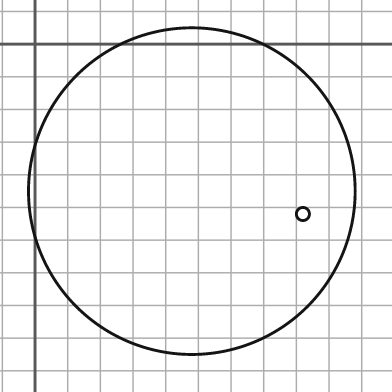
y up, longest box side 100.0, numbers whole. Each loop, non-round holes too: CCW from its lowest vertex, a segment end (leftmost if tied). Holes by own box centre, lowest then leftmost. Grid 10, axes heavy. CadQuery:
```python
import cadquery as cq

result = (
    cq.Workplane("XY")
    .moveTo(48.0, -45.0)
    .circle(50.0)
    .moveTo(82.0, -52.0)
    .circle(2.0)
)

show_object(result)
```